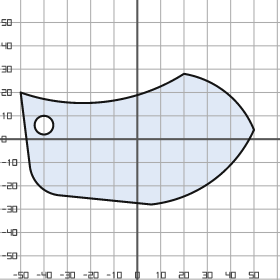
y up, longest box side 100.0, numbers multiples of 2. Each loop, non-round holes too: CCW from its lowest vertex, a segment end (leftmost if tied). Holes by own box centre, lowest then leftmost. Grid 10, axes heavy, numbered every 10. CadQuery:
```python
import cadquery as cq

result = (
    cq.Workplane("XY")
    .moveTo(6.0, -28.0)
    .threePointArc((32.0, -18.0), (50.0, 4.0))
    .threePointArc((38.0, 20.0), (20.0, 28.0))
    .threePointArc((-14.0, 16.0), (-50.0, 20.0))
    .lineTo(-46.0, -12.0)
    .threePointArc((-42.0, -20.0), (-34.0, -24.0))
    .close()
    .moveTo(-40.0, 6.0)
    .circle(4.0)
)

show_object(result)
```